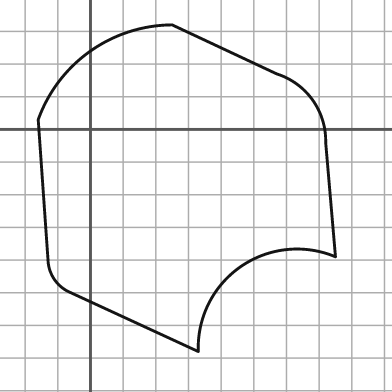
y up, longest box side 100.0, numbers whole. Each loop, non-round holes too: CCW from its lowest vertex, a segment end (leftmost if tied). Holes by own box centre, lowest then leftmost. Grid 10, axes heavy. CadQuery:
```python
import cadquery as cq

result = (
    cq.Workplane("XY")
    .moveTo(33.0, -68.0)
    .threePointArc((46.0, -42.0), (75.0, -39.0))
    .lineTo(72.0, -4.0)
    .threePointArc((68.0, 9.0), (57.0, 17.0))
    .lineTo(25.0, 32.0)
    .threePointArc((0.0, 24.0), (-16.0, 3.0))
    .lineTo(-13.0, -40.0)
    .threePointArc((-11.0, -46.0), (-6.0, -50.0))
    .close()
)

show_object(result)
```